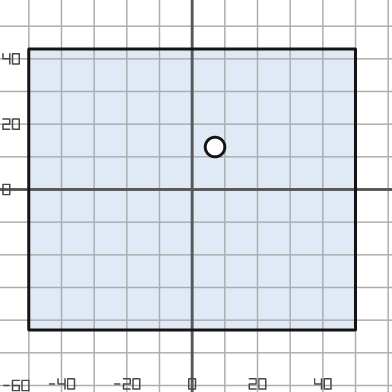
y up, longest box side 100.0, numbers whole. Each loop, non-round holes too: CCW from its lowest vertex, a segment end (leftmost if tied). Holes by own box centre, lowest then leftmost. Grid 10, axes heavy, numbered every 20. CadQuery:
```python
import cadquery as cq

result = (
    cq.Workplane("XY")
    .moveTo(-50.0, -43.0)
    .lineTo(50.0, -43.0)
    .lineTo(50.0, 43.0)
    .lineTo(-50.0, 43.0)
    .close()
    .moveTo(7.0, 13.0)
    .circle(3.0)
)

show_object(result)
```